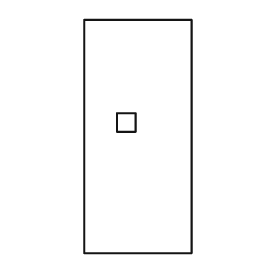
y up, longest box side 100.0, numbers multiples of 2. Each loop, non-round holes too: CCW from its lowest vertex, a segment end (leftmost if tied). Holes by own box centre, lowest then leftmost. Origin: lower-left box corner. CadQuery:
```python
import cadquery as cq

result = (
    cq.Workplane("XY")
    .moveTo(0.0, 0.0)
    .lineTo(46.0, 0.0)
    .lineTo(46.0, 100.0)
    .lineTo(0.0, 100.0)
    .close()
    .moveTo(14.0, 52.0)
    .lineTo(22.0, 52.0)
    .lineTo(22.0, 60.0)
    .lineTo(14.0, 60.0)
    .close()
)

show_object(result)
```